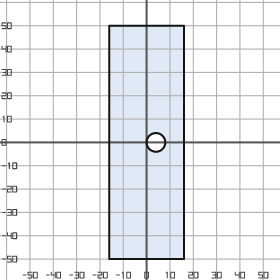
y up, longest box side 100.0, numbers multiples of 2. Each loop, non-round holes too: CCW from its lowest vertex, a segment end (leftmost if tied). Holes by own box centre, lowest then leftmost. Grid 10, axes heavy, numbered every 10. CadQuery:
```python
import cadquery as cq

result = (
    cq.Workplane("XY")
    .moveTo(-16.0, -50.0)
    .lineTo(16.0, -50.0)
    .lineTo(16.0, 50.0)
    .lineTo(-16.0, 50.0)
    .close()
    .moveTo(4.0, 0.0)
    .circle(4.0)
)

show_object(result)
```